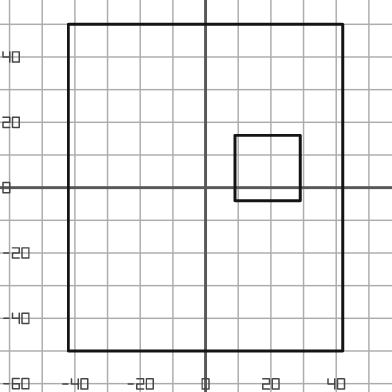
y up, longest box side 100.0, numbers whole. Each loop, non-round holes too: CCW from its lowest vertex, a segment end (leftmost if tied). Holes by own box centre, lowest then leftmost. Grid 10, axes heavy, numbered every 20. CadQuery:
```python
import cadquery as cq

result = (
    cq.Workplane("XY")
    .moveTo(-42.0, -50.0)
    .lineTo(42.0, -50.0)
    .lineTo(42.0, 50.0)
    .lineTo(-42.0, 50.0)
    .close()
    .moveTo(9.0, -4.0)
    .lineTo(29.0, -4.0)
    .lineTo(29.0, 16.0)
    .lineTo(9.0, 16.0)
    .close()
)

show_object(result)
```